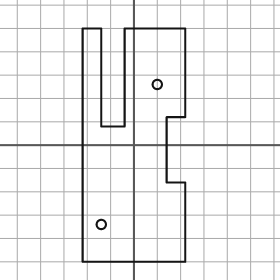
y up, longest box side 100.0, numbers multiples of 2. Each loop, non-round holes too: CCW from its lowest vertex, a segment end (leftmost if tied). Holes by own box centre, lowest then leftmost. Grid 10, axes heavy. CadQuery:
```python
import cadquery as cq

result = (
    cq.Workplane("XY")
    .moveTo(-22.0, -50.0)
    .lineTo(22.0, -50.0)
    .lineTo(22.0, -16.0)
    .lineTo(14.0, -16.0)
    .lineTo(14.0, 12.0)
    .lineTo(22.0, 12.0)
    .lineTo(22.0, 50.0)
    .lineTo(-4.0, 50.0)
    .lineTo(-4.0, 8.0)
    .lineTo(-14.0, 8.0)
    .lineTo(-14.0, 50.0)
    .lineTo(-22.0, 50.0)
    .close()
    .moveTo(-14.0, -34.0)
    .circle(2.0)
    .moveTo(10.0, 26.0)
    .circle(2.0)
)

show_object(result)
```